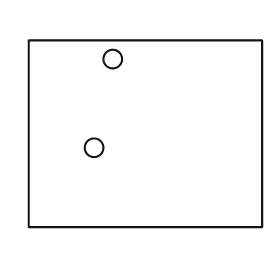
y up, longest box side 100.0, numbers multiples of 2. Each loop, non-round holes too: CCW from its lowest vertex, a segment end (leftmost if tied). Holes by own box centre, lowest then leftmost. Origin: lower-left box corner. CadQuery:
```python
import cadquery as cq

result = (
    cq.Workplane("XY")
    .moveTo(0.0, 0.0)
    .lineTo(100.0, 0.0)
    .lineTo(100.0, 80.0)
    .lineTo(0.0, 80.0)
    .close()
    .moveTo(28.0, 34.0)
    .circle(4.0)
    .moveTo(36.0, 72.0)
    .circle(4.0)
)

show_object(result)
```